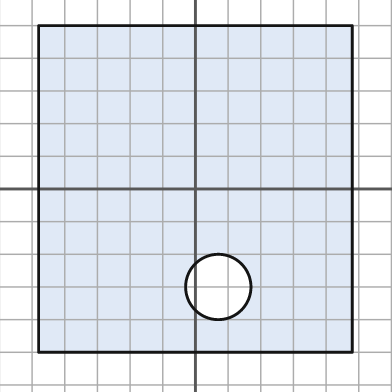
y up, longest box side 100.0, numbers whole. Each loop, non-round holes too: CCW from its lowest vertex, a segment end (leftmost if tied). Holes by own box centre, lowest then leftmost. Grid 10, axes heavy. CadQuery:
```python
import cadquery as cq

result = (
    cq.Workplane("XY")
    .moveTo(-48.0, -50.0)
    .lineTo(48.0, -50.0)
    .lineTo(48.0, 50.0)
    .lineTo(-48.0, 50.0)
    .close()
    .moveTo(7.0, -30.0)
    .circle(10.0)
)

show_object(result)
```